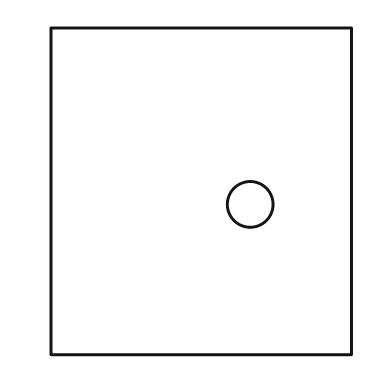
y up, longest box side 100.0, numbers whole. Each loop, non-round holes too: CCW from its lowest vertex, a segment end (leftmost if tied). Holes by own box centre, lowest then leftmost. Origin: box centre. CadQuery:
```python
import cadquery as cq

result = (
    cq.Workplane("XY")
    .moveTo(-46.0, -50.0)
    .lineTo(46.0, -50.0)
    .lineTo(46.0, 50.0)
    .lineTo(-46.0, 50.0)
    .close()
    .moveTo(15.0, -4.0)
    .circle(7.0)
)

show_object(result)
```